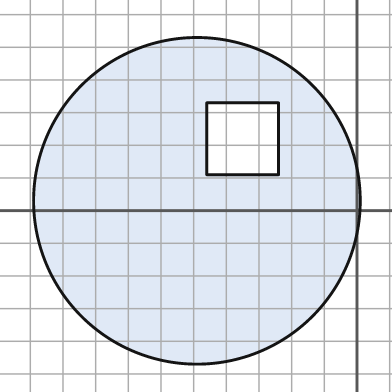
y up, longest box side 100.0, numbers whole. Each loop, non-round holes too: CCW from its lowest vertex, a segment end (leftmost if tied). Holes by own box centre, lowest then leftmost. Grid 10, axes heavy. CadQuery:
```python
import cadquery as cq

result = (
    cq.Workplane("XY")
    .moveTo(-49.0, 3.0)
    .circle(50.0)
    .moveTo(-46.0, 11.0)
    .lineTo(-24.0, 11.0)
    .lineTo(-24.0, 33.0)
    .lineTo(-46.0, 33.0)
    .close()
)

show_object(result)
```